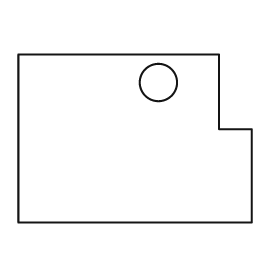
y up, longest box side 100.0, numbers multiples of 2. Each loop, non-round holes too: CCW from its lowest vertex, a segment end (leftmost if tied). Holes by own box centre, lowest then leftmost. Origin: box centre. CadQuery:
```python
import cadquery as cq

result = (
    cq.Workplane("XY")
    .moveTo(-50.0, -36.0)
    .lineTo(50.0, -36.0)
    .lineTo(50.0, 4.0)
    .lineTo(36.0, 4.0)
    .lineTo(36.0, 36.0)
    .lineTo(-50.0, 36.0)
    .close()
    .moveTo(10.0, 24.0)
    .circle(8.0)
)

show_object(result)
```